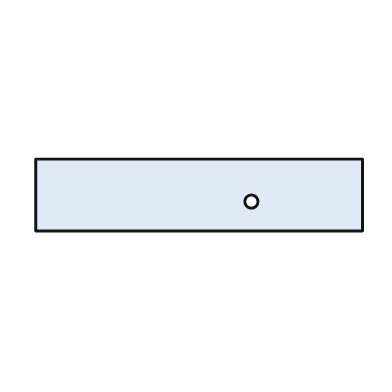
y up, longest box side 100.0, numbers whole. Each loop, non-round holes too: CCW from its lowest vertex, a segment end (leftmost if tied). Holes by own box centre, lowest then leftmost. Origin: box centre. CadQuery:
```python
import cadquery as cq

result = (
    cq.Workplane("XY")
    .moveTo(-50.0, -11.0)
    .lineTo(50.0, -11.0)
    .lineTo(50.0, 11.0)
    .lineTo(-50.0, 11.0)
    .close()
    .moveTo(16.0, -2.0)
    .circle(2.0)
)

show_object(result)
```